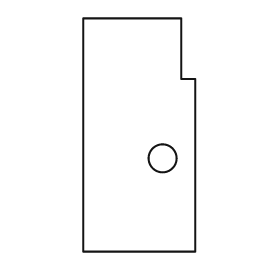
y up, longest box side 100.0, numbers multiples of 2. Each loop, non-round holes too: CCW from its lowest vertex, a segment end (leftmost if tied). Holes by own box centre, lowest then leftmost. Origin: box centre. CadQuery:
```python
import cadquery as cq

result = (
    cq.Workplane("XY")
    .moveTo(-24.0, -50.0)
    .lineTo(24.0, -50.0)
    .lineTo(24.0, 24.0)
    .lineTo(18.0, 24.0)
    .lineTo(18.0, 50.0)
    .lineTo(-24.0, 50.0)
    .close()
    .moveTo(10.0, -10.0)
    .circle(6.0)
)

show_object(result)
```